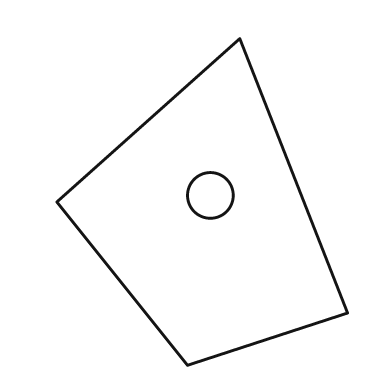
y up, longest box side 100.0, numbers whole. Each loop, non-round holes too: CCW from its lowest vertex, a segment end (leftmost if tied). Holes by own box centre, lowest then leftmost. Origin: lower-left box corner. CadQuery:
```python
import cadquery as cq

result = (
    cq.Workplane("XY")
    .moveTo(40.0, 0.0)
    .lineTo(89.0, 16.0)
    .lineTo(56.0, 100.0)
    .lineTo(0.0, 50.0)
    .close()
    .moveTo(47.0, 52.0)
    .circle(7.0)
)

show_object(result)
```